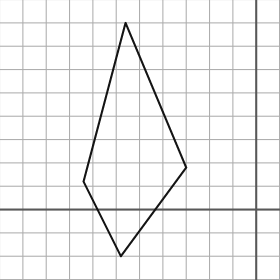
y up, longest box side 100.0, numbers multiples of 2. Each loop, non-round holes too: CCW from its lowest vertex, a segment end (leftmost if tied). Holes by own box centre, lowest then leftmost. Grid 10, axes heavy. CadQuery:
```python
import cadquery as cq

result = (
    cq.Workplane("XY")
    .moveTo(-58.0, -20.0)
    .lineTo(-30.0, 18.0)
    .lineTo(-56.0, 80.0)
    .lineTo(-74.0, 12.0)
    .close()
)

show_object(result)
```